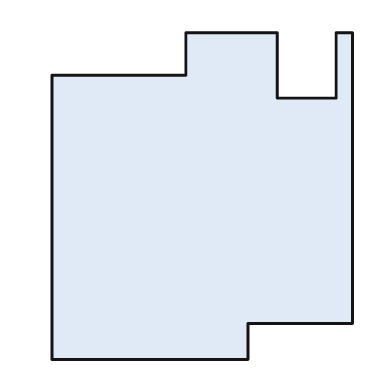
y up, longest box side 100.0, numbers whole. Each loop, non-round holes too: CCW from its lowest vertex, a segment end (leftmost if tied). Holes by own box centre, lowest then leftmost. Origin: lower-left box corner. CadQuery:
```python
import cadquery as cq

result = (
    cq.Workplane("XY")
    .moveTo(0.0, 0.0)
    .lineTo(60.0, 0.0)
    .lineTo(60.0, 11.0)
    .lineTo(92.0, 11.0)
    .lineTo(92.0, 100.0)
    .lineTo(87.0, 100.0)
    .lineTo(87.0, 80.0)
    .lineTo(69.0, 80.0)
    .lineTo(69.0, 100.0)
    .lineTo(41.0, 100.0)
    .lineTo(41.0, 87.0)
    .lineTo(0.0, 87.0)
    .close()
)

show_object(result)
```